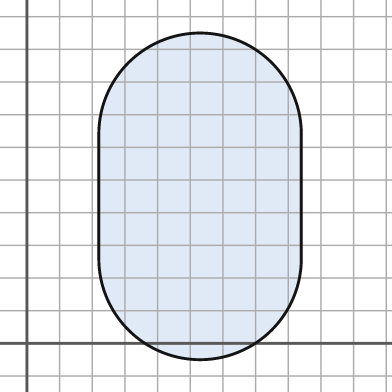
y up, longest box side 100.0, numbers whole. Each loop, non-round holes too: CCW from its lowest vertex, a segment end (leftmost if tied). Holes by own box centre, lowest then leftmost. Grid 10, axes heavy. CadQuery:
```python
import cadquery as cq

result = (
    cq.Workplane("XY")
    .moveTo(22.0, 26.0)
    .threePointArc((53.0, -5.0), (84.0, 26.0))
    .lineTo(84.0, 64.0)
    .threePointArc((53.0, 95.0), (22.0, 64.0))
    .close()
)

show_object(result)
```